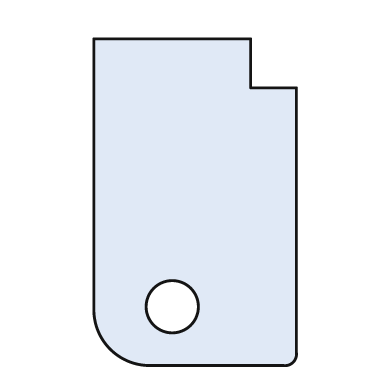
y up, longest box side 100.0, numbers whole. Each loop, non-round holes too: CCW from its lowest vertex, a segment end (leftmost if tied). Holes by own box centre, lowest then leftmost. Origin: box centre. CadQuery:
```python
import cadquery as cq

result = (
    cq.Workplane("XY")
    .moveTo(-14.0, -50.0)
    .lineTo(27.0, -50.0)
    .threePointArc((30.0, -49.0), (31.0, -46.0))
    .lineTo(31.0, 35.0)
    .lineTo(17.0, 35.0)
    .lineTo(17.0, 50.0)
    .lineTo(-31.0, 50.0)
    .lineTo(-31.0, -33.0)
    .threePointArc((-26.0, -45.0), (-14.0, -50.0))
    .close()
    .moveTo(-7.0, -32.0)
    .circle(8.0)
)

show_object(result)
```